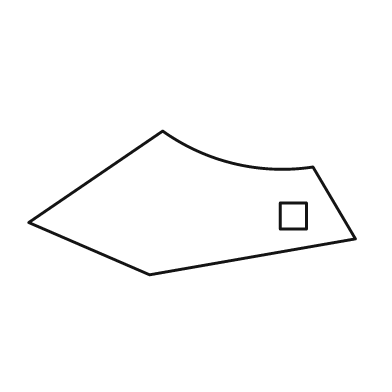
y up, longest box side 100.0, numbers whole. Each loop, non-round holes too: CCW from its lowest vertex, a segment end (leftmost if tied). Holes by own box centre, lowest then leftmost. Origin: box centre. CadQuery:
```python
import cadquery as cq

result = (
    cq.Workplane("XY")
    .moveTo(-13.0, -22.0)
    .lineTo(50.0, -11.0)
    .lineTo(37.0, 11.0)
    .threePointArc((13.0, 12.0), (-9.0, 22.0))
    .lineTo(-50.0, -6.0)
    .close()
    .moveTo(27.0, -8.0)
    .lineTo(35.0, -8.0)
    .lineTo(35.0, 0.0)
    .lineTo(27.0, 0.0)
    .close()
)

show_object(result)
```